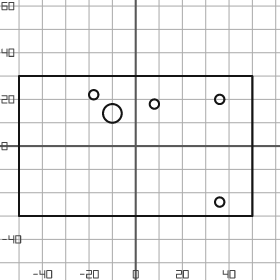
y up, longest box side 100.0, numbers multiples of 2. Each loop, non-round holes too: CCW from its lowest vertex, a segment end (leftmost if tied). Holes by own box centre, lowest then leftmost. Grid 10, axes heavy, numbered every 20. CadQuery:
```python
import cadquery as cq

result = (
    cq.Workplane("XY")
    .moveTo(-50.0, -30.0)
    .lineTo(50.0, -30.0)
    .lineTo(50.0, 30.0)
    .lineTo(-50.0, 30.0)
    .close()
    .moveTo(36.0, -24.0)
    .circle(2.0)
    .moveTo(-10.0, 14.0)
    .circle(4.0)
    .moveTo(8.0, 18.0)
    .circle(2.0)
    .moveTo(36.0, 20.0)
    .circle(2.0)
    .moveTo(-18.0, 22.0)
    .circle(2.0)
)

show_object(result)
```